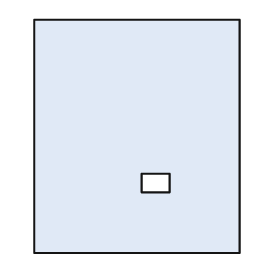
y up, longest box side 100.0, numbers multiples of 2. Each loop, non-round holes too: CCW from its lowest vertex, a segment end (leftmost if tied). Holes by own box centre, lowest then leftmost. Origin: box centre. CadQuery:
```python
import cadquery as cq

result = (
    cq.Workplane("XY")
    .moveTo(-44.0, -50.0)
    .lineTo(44.0, -50.0)
    .lineTo(44.0, 50.0)
    .lineTo(-44.0, 50.0)
    .close()
    .moveTo(2.0, -24.0)
    .lineTo(14.0, -24.0)
    .lineTo(14.0, -16.0)
    .lineTo(2.0, -16.0)
    .close()
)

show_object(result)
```